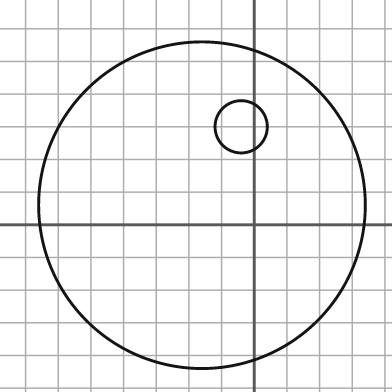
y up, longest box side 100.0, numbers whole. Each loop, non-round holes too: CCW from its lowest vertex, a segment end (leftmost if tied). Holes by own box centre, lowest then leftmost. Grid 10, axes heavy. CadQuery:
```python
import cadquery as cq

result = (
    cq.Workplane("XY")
    .moveTo(-16.0, 6.0)
    .circle(50.0)
    .moveTo(-4.0, 30.0)
    .circle(8.0)
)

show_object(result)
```